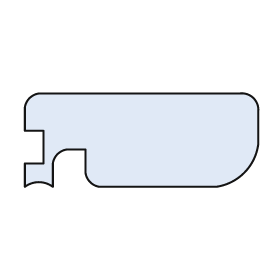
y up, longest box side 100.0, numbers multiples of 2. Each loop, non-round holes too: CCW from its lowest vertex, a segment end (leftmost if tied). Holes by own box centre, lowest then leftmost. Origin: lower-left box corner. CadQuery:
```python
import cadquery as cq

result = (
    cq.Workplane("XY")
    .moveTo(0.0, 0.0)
    .threePointArc((6.0, 2.0), (12.0, 0.0))
    .lineTo(12.0, 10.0)
    .threePointArc((14.0, 14.0), (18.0, 16.0))
    .lineTo(26.0, 16.0)
    .lineTo(26.0, 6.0)
    .threePointArc((28.0, 2.0), (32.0, 0.0))
    .lineTo(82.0, 0.0)
    .threePointArc((94.0, 6.0), (100.0, 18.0))
    .lineTo(100.0, 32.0)
    .threePointArc((98.0, 38.0), (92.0, 40.0))
    .lineTo(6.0, 40.0)
    .threePointArc((2.0, 38.0), (0.0, 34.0))
    .lineTo(0.0, 24.0)
    .lineTo(8.0, 24.0)
    .lineTo(8.0, 10.0)
    .lineTo(0.0, 10.0)
    .close()
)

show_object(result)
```